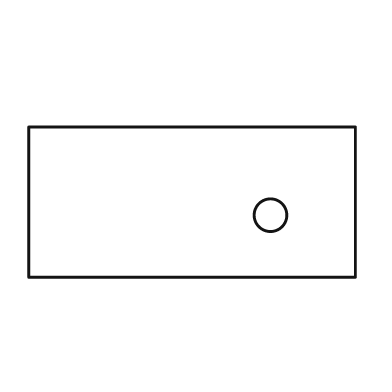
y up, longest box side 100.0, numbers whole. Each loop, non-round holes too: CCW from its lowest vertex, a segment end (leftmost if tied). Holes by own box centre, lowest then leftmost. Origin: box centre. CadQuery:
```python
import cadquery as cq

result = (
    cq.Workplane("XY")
    .moveTo(-50.0, -23.0)
    .lineTo(50.0, -23.0)
    .lineTo(50.0, 23.0)
    .lineTo(-50.0, 23.0)
    .close()
    .moveTo(24.0, -4.0)
    .circle(5.0)
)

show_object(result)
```